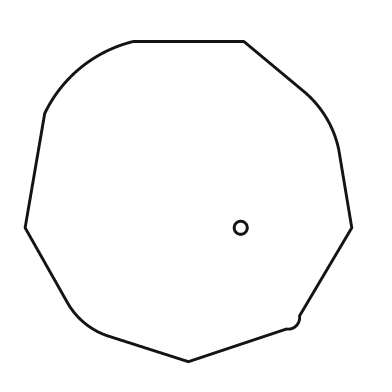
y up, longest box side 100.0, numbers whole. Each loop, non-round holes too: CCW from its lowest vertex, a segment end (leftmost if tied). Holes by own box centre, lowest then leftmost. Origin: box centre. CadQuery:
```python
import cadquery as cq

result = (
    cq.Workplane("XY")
    .moveTo(0.0, -49.0)
    .lineTo(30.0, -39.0)
    .threePointArc((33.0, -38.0), (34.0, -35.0))
    .lineTo(50.0, -8.0)
    .lineTo(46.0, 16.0)
    .threePointArc((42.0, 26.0), (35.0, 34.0))
    .lineTo(17.0, 49.0)
    .lineTo(-17.0, 49.0)
    .threePointArc((-33.0, 41.0), (-44.0, 27.0))
    .lineTo(-50.0, -8.0)
    .lineTo(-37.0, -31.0)
    .threePointArc((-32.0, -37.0), (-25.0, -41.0))
    .close()
    .moveTo(16.0, -8.0)
    .circle(2.0)
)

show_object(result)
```